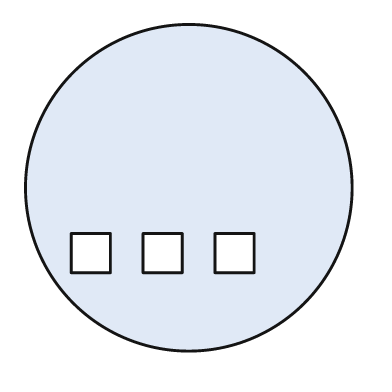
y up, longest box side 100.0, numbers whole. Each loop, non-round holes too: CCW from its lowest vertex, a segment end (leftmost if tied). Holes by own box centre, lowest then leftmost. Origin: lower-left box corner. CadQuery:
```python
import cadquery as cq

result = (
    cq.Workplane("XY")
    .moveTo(50.0, 50.0)
    .circle(50.0)
    .moveTo(14.0, 24.0)
    .lineTo(26.0, 24.0)
    .lineTo(26.0, 36.0)
    .lineTo(14.0, 36.0)
    .close()
    .moveTo(36.0, 24.0)
    .lineTo(48.0, 24.0)
    .lineTo(48.0, 36.0)
    .lineTo(36.0, 36.0)
    .close()
    .moveTo(58.0, 24.0)
    .lineTo(70.0, 24.0)
    .lineTo(70.0, 36.0)
    .lineTo(58.0, 36.0)
    .close()
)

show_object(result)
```